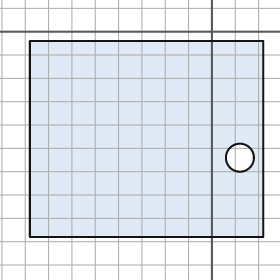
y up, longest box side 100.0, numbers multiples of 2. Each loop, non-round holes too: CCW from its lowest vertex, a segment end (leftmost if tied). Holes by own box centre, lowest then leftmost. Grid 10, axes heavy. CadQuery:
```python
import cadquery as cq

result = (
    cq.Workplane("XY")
    .moveTo(-78.0, -88.0)
    .lineTo(22.0, -88.0)
    .lineTo(22.0, -4.0)
    .lineTo(-78.0, -4.0)
    .close()
    .moveTo(12.0, -54.0)
    .circle(6.0)
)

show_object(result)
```